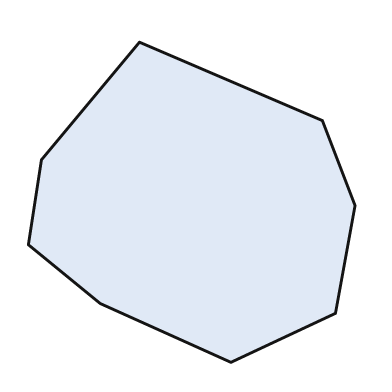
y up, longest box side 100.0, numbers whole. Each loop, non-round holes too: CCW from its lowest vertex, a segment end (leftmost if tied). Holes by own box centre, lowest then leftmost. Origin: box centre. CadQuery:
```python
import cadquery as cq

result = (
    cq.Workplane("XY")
    .moveTo(12.0, -49.0)
    .lineTo(44.0, -34.0)
    .lineTo(50.0, -1.0)
    .lineTo(40.0, 25.0)
    .lineTo(-16.0, 49.0)
    .lineTo(-46.0, 13.0)
    .lineTo(-50.0, -13.0)
    .lineTo(-28.0, -31.0)
    .close()
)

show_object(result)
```